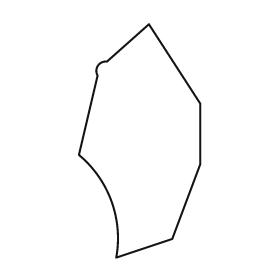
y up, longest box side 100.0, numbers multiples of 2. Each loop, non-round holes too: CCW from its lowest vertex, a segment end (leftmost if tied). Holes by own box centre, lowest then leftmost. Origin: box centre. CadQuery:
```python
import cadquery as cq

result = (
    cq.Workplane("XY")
    .moveTo(-10.0, -50.0)
    .lineTo(14.0, -42.0)
    .lineTo(26.0, -10.0)
    .lineTo(26.0, 16.0)
    .lineTo(4.0, 50.0)
    .lineTo(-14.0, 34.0)
    .threePointArc((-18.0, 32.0), (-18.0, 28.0))
    .lineTo(-26.0, -6.0)
    .threePointArc((-12.0, -26.0), (-10.0, -50.0))
    .close()
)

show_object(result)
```